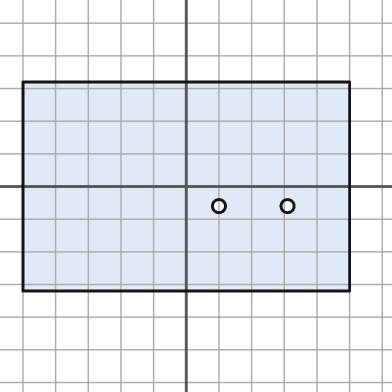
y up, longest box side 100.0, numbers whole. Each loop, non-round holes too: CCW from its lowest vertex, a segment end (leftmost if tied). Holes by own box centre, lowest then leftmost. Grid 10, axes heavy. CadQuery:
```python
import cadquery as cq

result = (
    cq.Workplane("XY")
    .moveTo(-50.0, -32.0)
    .lineTo(50.0, -32.0)
    .lineTo(50.0, 32.0)
    .lineTo(-50.0, 32.0)
    .close()
    .moveTo(10.0, -6.0)
    .circle(2.0)
    .moveTo(31.0, -6.0)
    .circle(2.0)
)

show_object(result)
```